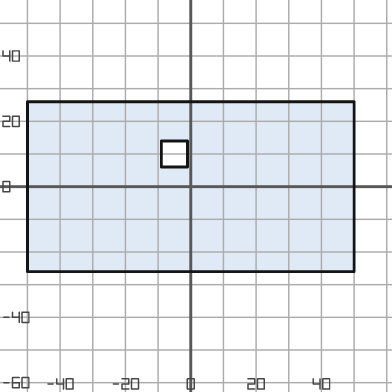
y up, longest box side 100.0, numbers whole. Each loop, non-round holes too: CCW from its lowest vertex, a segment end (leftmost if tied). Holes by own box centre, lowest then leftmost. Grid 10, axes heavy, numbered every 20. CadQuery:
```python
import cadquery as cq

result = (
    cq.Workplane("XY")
    .moveTo(-50.0, -26.0)
    .lineTo(50.0, -26.0)
    .lineTo(50.0, 26.0)
    .lineTo(-50.0, 26.0)
    .close()
    .moveTo(-9.0, 6.0)
    .lineTo(-1.0, 6.0)
    .lineTo(-1.0, 14.0)
    .lineTo(-9.0, 14.0)
    .close()
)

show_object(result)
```